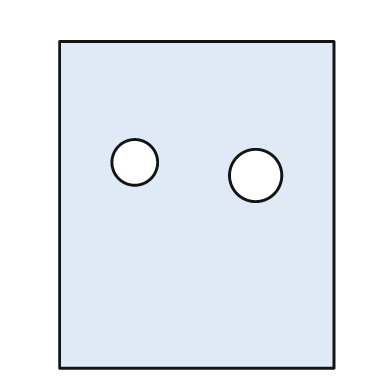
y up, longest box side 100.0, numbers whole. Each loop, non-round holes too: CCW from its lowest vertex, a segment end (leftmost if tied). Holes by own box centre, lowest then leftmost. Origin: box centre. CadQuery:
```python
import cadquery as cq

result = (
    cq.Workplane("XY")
    .moveTo(-42.0, -50.0)
    .lineTo(42.0, -50.0)
    .lineTo(42.0, 50.0)
    .lineTo(-42.0, 50.0)
    .close()
    .moveTo(18.0, 9.0)
    .circle(8.0)
    .moveTo(-19.0, 13.0)
    .circle(7.0)
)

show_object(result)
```